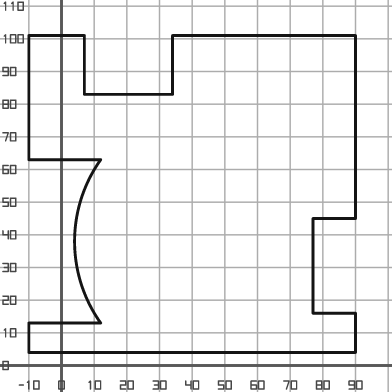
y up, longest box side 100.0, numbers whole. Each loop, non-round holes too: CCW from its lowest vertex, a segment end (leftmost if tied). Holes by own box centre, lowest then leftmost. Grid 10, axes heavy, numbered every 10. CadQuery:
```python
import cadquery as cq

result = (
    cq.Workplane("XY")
    .moveTo(-10.0, 4.0)
    .lineTo(90.0, 4.0)
    .lineTo(90.0, 16.0)
    .lineTo(77.0, 16.0)
    .lineTo(77.0, 45.0)
    .lineTo(90.0, 45.0)
    .lineTo(90.0, 101.0)
    .lineTo(34.0, 101.0)
    .lineTo(34.0, 83.0)
    .lineTo(7.0, 83.0)
    .lineTo(7.0, 101.0)
    .lineTo(-10.0, 101.0)
    .lineTo(-10.0, 63.0)
    .lineTo(12.0, 63.0)
    .threePointArc((4.0, 38.0), (12.0, 13.0))
    .lineTo(-10.0, 13.0)
    .close()
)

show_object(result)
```